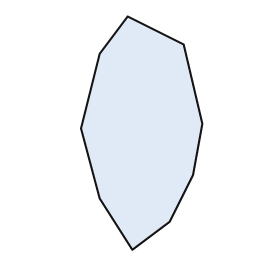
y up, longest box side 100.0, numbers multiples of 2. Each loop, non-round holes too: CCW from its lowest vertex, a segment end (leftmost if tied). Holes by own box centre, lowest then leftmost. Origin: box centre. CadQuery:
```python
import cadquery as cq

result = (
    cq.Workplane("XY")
    .moveTo(-4.0, -50.0)
    .lineTo(12.0, -38.0)
    .lineTo(22.0, -18.0)
    .lineTo(26.0, 4.0)
    .lineTo(18.0, 38.0)
    .lineTo(-6.0, 50.0)
    .lineTo(-18.0, 34.0)
    .lineTo(-26.0, 2.0)
    .lineTo(-18.0, -28.0)
    .close()
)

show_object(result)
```